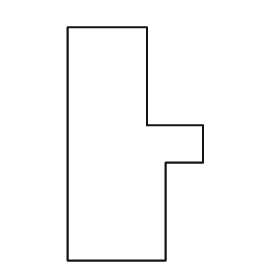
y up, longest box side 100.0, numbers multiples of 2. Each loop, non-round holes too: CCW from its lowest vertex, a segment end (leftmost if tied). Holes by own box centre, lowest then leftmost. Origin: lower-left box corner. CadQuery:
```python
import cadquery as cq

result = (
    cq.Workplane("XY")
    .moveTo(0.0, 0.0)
    .lineTo(42.0, 0.0)
    .lineTo(42.0, 42.0)
    .lineTo(58.0, 42.0)
    .lineTo(58.0, 58.0)
    .lineTo(34.0, 58.0)
    .lineTo(34.0, 100.0)
    .lineTo(0.0, 100.0)
    .close()
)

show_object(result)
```